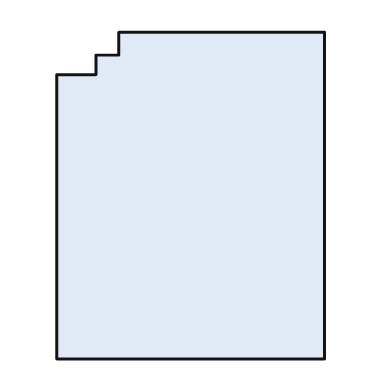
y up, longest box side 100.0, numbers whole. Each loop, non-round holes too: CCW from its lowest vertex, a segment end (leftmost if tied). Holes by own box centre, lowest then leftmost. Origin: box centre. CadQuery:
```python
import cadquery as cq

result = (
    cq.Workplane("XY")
    .moveTo(-41.0, -50.0)
    .lineTo(41.0, -50.0)
    .lineTo(41.0, 50.0)
    .lineTo(-22.0, 50.0)
    .lineTo(-22.0, 43.0)
    .lineTo(-29.0, 43.0)
    .lineTo(-29.0, 37.0)
    .lineTo(-41.0, 37.0)
    .close()
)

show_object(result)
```